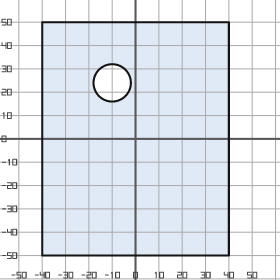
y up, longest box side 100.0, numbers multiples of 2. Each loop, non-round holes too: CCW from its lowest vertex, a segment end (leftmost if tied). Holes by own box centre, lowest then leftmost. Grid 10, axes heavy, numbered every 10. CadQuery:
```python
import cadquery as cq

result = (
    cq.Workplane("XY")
    .moveTo(-40.0, -50.0)
    .lineTo(40.0, -50.0)
    .lineTo(40.0, 50.0)
    .lineTo(-40.0, 50.0)
    .close()
    .moveTo(-10.0, 24.0)
    .circle(8.0)
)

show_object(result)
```